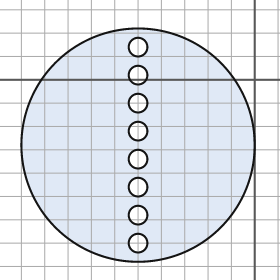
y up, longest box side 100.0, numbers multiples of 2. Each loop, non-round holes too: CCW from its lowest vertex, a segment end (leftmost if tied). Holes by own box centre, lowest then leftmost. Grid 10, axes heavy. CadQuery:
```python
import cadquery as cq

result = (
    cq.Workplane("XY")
    .moveTo(-50.0, -28.0)
    .circle(50.0)
    .moveTo(-50.0, -70.0)
    .circle(4.0)
    .moveTo(-50.0, -58.0)
    .circle(4.0)
    .moveTo(-50.0, -46.0)
    .circle(4.0)
    .moveTo(-50.0, -34.0)
    .circle(4.0)
    .moveTo(-50.0, -22.0)
    .circle(4.0)
    .moveTo(-50.0, -10.0)
    .circle(4.0)
    .moveTo(-50.0, 2.0)
    .circle(4.0)
    .moveTo(-50.0, 14.0)
    .circle(4.0)
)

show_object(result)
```